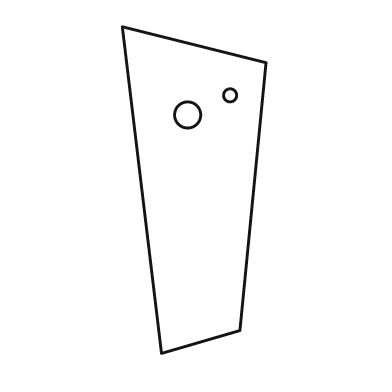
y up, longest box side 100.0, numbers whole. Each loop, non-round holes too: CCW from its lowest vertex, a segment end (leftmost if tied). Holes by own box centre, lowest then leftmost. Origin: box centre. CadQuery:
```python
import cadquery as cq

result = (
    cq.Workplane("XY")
    .moveTo(-10.0, -50.0)
    .lineTo(14.0, -43.0)
    .lineTo(22.0, 39.0)
    .lineTo(-22.0, 50.0)
    .close()
    .moveTo(-2.0, 23.0)
    .circle(4.0)
    .moveTo(11.0, 29.0)
    .circle(2.0)
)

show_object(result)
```